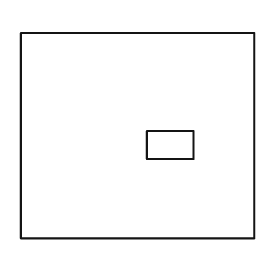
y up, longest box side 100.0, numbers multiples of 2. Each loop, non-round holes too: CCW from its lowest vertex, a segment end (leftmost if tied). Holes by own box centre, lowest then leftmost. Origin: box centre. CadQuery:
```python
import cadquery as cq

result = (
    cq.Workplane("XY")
    .moveTo(-50.0, -44.0)
    .lineTo(50.0, -44.0)
    .lineTo(50.0, 44.0)
    .lineTo(-50.0, 44.0)
    .close()
    .moveTo(4.0, -10.0)
    .lineTo(24.0, -10.0)
    .lineTo(24.0, 2.0)
    .lineTo(4.0, 2.0)
    .close()
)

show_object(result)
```